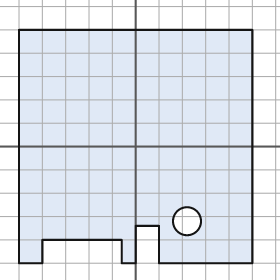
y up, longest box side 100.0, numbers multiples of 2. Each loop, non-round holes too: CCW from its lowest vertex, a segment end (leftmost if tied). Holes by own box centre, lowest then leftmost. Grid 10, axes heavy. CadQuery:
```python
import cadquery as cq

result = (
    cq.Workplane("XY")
    .moveTo(-50.0, -50.0)
    .lineTo(-40.0, -50.0)
    .lineTo(-40.0, -40.0)
    .lineTo(-6.0, -40.0)
    .lineTo(-6.0, -50.0)
    .lineTo(0.0, -50.0)
    .lineTo(0.0, -34.0)
    .lineTo(10.0, -34.0)
    .lineTo(10.0, -50.0)
    .lineTo(50.0, -50.0)
    .lineTo(50.0, 50.0)
    .lineTo(-50.0, 50.0)
    .close()
    .moveTo(22.0, -32.0)
    .circle(6.0)
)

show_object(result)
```